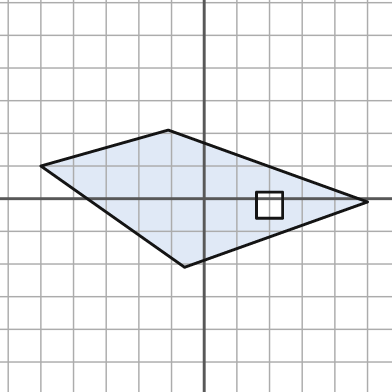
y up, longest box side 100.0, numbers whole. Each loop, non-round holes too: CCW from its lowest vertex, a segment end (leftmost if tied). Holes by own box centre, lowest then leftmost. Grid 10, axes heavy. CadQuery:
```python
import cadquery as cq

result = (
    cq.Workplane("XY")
    .moveTo(-6.0, -21.0)
    .lineTo(50.0, -1.0)
    .lineTo(-11.0, 21.0)
    .lineTo(-50.0, 10.0)
    .close()
    .moveTo(16.0, -6.0)
    .lineTo(24.0, -6.0)
    .lineTo(24.0, 2.0)
    .lineTo(16.0, 2.0)
    .close()
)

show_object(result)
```